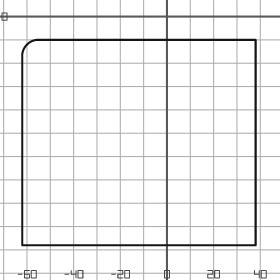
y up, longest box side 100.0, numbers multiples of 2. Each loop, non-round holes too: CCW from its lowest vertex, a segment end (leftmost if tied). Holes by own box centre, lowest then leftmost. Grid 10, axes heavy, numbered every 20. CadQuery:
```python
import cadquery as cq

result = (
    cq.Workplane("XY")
    .moveTo(-62.0, -98.0)
    .lineTo(38.0, -98.0)
    .lineTo(38.0, -10.0)
    .lineTo(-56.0, -10.0)
    .threePointArc((-60.0, -12.0), (-62.0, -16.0))
    .close()
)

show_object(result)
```